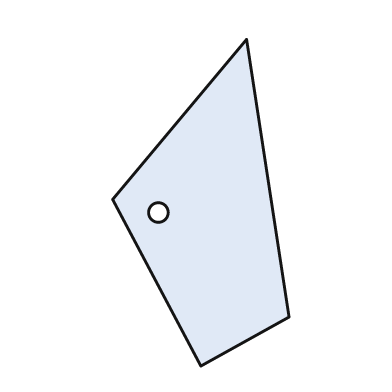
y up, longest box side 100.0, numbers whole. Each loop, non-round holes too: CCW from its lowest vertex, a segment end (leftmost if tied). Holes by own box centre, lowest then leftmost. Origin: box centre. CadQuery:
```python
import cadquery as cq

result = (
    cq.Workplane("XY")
    .moveTo(0.0, -50.0)
    .lineTo(27.0, -35.0)
    .lineTo(14.0, 50.0)
    .lineTo(-27.0, 1.0)
    .close()
    .moveTo(-13.0, -3.0)
    .circle(3.0)
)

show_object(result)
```